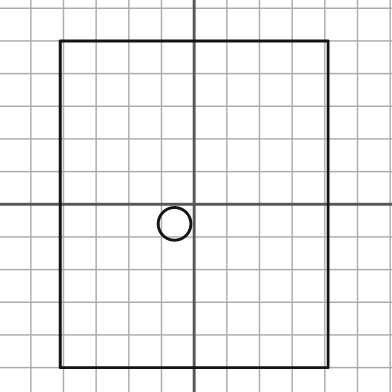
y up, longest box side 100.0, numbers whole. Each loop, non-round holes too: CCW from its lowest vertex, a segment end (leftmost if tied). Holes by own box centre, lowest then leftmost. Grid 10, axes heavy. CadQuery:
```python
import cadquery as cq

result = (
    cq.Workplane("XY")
    .moveTo(-41.0, -50.0)
    .lineTo(41.0, -50.0)
    .lineTo(41.0, 50.0)
    .lineTo(-41.0, 50.0)
    .close()
    .moveTo(-6.0, -6.0)
    .circle(5.0)
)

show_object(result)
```